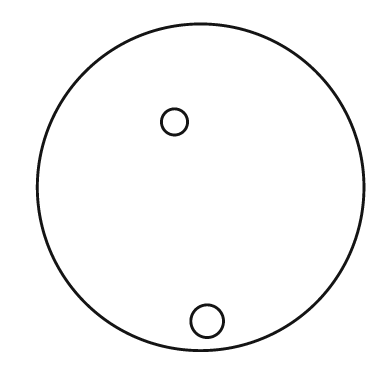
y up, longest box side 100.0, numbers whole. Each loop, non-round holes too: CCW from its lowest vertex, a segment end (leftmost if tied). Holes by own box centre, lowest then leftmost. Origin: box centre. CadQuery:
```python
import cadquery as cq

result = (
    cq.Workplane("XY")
    .moveTo(0.0, 0.0)
    .circle(50.0)
    .moveTo(2.0, -41.0)
    .circle(5.0)
    .moveTo(-8.0, 20.0)
    .circle(4.0)
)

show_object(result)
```